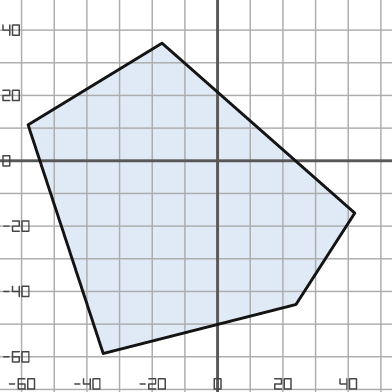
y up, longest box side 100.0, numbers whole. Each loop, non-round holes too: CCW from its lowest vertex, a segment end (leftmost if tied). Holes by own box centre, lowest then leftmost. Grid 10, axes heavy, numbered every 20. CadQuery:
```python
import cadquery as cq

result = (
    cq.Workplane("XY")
    .moveTo(-35.0, -59.0)
    .lineTo(24.0, -44.0)
    .lineTo(42.0, -16.0)
    .lineTo(-17.0, 36.0)
    .lineTo(-58.0, 11.0)
    .close()
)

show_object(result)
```